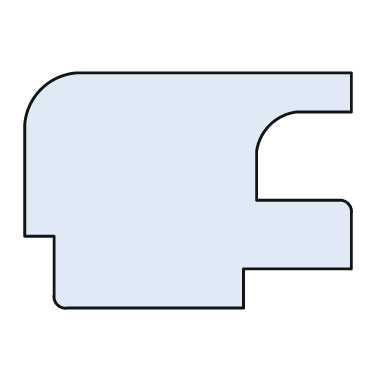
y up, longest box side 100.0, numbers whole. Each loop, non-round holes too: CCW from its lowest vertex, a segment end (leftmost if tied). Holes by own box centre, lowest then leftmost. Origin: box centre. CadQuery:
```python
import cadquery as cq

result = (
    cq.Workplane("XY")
    .moveTo(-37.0, -36.0)
    .lineTo(17.0, -36.0)
    .lineTo(17.0, -24.0)
    .lineTo(50.0, -24.0)
    .lineTo(50.0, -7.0)
    .threePointArc((49.0, -4.0), (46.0, -3.0))
    .lineTo(21.0, -3.0)
    .lineTo(21.0, 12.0)
    .threePointArc((25.0, 20.0), (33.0, 24.0))
    .lineTo(50.0, 24.0)
    .lineTo(50.0, 36.0)
    .lineTo(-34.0, 36.0)
    .threePointArc((-45.0, 31.0), (-50.0, 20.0))
    .lineTo(-50.0, -14.0)
    .lineTo(-41.0, -14.0)
    .lineTo(-41.0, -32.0)
    .threePointArc((-40.0, -35.0), (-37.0, -36.0))
    .close()
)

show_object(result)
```